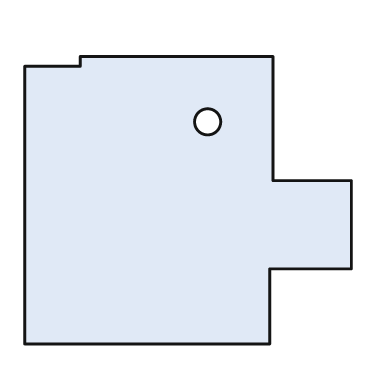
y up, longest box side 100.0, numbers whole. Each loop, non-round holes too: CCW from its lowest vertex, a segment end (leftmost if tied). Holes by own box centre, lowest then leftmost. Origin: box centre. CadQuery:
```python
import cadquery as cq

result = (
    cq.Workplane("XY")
    .moveTo(-50.0, -44.0)
    .lineTo(25.0, -44.0)
    .lineTo(25.0, -21.0)
    .lineTo(50.0, -21.0)
    .lineTo(50.0, 6.0)
    .lineTo(26.0, 6.0)
    .lineTo(26.0, 44.0)
    .lineTo(-33.0, 44.0)
    .lineTo(-33.0, 41.0)
    .lineTo(-50.0, 41.0)
    .close()
    .moveTo(6.0, 24.0)
    .circle(4.0)
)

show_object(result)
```